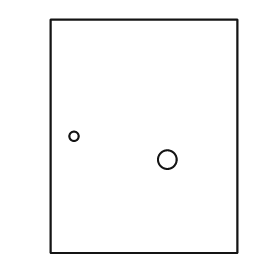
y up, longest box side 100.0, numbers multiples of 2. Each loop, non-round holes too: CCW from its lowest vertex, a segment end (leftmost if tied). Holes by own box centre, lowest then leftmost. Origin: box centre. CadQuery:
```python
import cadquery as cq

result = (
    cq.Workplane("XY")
    .moveTo(-40.0, -50.0)
    .lineTo(40.0, -50.0)
    .lineTo(40.0, 50.0)
    .lineTo(-40.0, 50.0)
    .close()
    .moveTo(10.0, -10.0)
    .circle(4.0)
    .moveTo(-30.0, 0.0)
    .circle(2.0)
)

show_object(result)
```